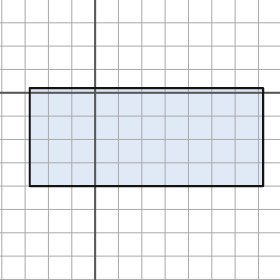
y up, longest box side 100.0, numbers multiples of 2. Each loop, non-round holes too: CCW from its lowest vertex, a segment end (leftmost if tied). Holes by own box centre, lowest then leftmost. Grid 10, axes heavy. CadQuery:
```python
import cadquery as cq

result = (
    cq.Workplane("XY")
    .moveTo(-28.0, -40.0)
    .lineTo(72.0, -40.0)
    .lineTo(72.0, 2.0)
    .lineTo(-28.0, 2.0)
    .close()
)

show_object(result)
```